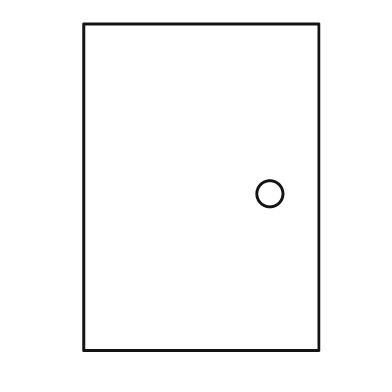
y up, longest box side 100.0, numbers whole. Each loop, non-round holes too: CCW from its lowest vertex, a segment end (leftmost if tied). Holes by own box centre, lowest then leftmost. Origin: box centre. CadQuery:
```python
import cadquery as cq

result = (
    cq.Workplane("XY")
    .moveTo(-36.0, -50.0)
    .lineTo(36.0, -50.0)
    .lineTo(36.0, 50.0)
    .lineTo(-36.0, 50.0)
    .close()
    .moveTo(21.0, -2.0)
    .circle(4.0)
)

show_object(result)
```